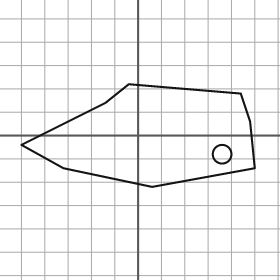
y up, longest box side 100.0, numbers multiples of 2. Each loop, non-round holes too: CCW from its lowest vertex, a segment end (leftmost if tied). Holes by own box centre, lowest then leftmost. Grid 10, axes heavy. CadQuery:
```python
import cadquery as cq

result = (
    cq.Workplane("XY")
    .moveTo(6.0, -22.0)
    .lineTo(50.0, -14.0)
    .lineTo(48.0, 6.0)
    .lineTo(44.0, 18.0)
    .lineTo(-4.0, 22.0)
    .lineTo(-14.0, 14.0)
    .lineTo(-50.0, -4.0)
    .lineTo(-32.0, -14.0)
    .close()
    .moveTo(36.0, -8.0)
    .circle(4.0)
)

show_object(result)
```